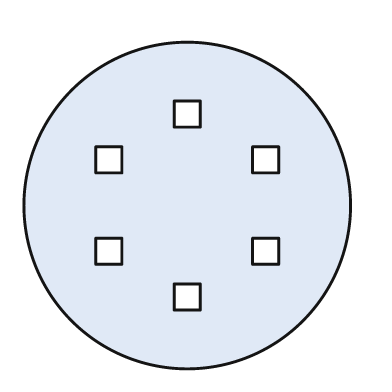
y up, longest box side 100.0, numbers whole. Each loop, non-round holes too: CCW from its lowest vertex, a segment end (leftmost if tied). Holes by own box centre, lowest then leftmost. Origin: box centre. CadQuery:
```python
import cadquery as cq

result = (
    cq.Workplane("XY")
    .moveTo(0.0, 0.0)
    .circle(50.0)
    .moveTo(-4.0, -32.0)
    .lineTo(4.0, -32.0)
    .lineTo(4.0, -24.0)
    .lineTo(-4.0, -24.0)
    .close()
    .moveTo(-28.0, -18.0)
    .lineTo(-20.0, -18.0)
    .lineTo(-20.0, -10.0)
    .lineTo(-28.0, -10.0)
    .close()
    .moveTo(20.0, -18.0)
    .lineTo(28.0, -18.0)
    .lineTo(28.0, -10.0)
    .lineTo(20.0, -10.0)
    .close()
    .moveTo(-28.0, 10.0)
    .lineTo(-20.0, 10.0)
    .lineTo(-20.0, 18.0)
    .lineTo(-28.0, 18.0)
    .close()
    .moveTo(20.0, 10.0)
    .lineTo(28.0, 10.0)
    .lineTo(28.0, 18.0)
    .lineTo(20.0, 18.0)
    .close()
    .moveTo(-4.0, 24.0)
    .lineTo(4.0, 24.0)
    .lineTo(4.0, 32.0)
    .lineTo(-4.0, 32.0)
    .close()
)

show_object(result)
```